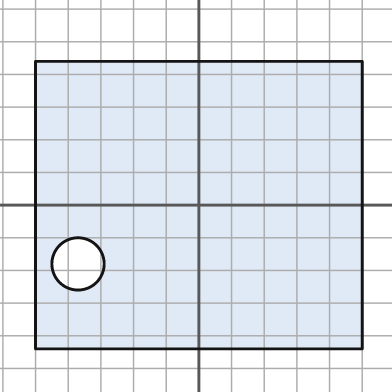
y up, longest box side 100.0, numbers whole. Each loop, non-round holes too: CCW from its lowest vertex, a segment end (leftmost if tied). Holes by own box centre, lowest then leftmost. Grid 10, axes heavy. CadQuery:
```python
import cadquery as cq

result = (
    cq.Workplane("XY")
    .moveTo(-50.0, -44.0)
    .lineTo(50.0, -44.0)
    .lineTo(50.0, 44.0)
    .lineTo(-50.0, 44.0)
    .close()
    .moveTo(-37.0, -18.0)
    .circle(8.0)
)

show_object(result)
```